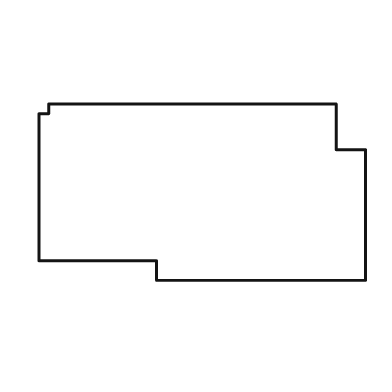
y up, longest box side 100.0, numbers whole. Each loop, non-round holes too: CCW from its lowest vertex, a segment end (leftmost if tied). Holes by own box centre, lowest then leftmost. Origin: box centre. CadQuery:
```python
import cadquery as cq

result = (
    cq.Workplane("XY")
    .moveTo(-14.0, -27.0)
    .lineTo(50.0, -27.0)
    .lineTo(50.0, 13.0)
    .lineTo(41.0, 13.0)
    .lineTo(41.0, 27.0)
    .lineTo(-47.0, 27.0)
    .lineTo(-47.0, 24.0)
    .lineTo(-50.0, 24.0)
    .lineTo(-50.0, -21.0)
    .lineTo(-14.0, -21.0)
    .close()
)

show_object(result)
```